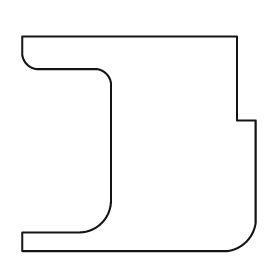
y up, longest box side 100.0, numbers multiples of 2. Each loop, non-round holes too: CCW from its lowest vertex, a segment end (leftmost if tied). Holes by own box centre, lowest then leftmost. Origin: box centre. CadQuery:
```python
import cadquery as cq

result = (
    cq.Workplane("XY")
    .moveTo(-50.0, -46.0)
    .lineTo(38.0, -46.0)
    .threePointArc((46.0, -42.0), (50.0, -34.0))
    .lineTo(50.0, 10.0)
    .lineTo(42.0, 10.0)
    .lineTo(42.0, 46.0)
    .lineTo(-50.0, 46.0)
    .lineTo(-50.0, 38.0)
    .threePointArc((-48.0, 34.0), (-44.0, 32.0))
    .lineTo(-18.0, 32.0)
    .threePointArc((-14.0, 30.0), (-12.0, 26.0))
    .lineTo(-12.0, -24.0)
    .threePointArc((-16.0, -34.0), (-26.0, -38.0))
    .lineTo(-50.0, -38.0)
    .close()
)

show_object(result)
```